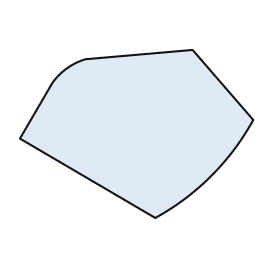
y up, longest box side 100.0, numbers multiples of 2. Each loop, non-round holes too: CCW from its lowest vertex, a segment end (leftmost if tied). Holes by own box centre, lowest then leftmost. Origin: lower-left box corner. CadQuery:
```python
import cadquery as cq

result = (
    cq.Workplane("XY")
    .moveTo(58.0, 0.0)
    .threePointArc((82.0, 18.0), (100.0, 42.0))
    .lineTo(74.0, 72.0)
    .lineTo(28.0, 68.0)
    .threePointArc((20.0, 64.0), (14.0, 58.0))
    .lineTo(0.0, 34.0)
    .close()
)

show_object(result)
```